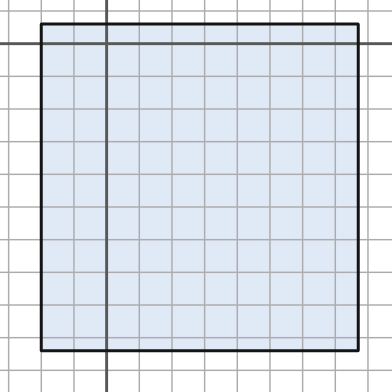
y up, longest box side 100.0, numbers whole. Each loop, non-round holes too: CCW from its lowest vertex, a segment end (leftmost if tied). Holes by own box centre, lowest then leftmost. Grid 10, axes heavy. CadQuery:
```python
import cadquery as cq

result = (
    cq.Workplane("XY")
    .moveTo(-20.0, -94.0)
    .lineTo(77.0, -94.0)
    .lineTo(77.0, 6.0)
    .lineTo(-20.0, 6.0)
    .close()
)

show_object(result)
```